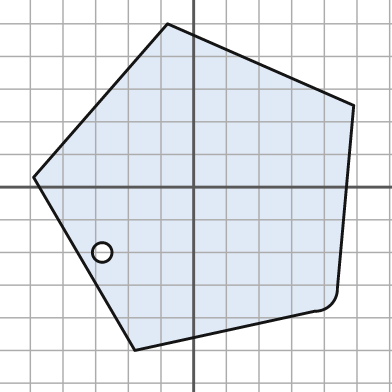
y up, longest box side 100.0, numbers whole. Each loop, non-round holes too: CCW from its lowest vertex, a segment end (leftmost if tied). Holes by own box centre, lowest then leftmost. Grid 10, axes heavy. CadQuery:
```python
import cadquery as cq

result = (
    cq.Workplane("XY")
    .moveTo(-18.0, -50.0)
    .lineTo(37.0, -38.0)
    .threePointArc((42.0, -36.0), (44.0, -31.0))
    .lineTo(49.0, 25.0)
    .lineTo(-8.0, 50.0)
    .lineTo(-49.0, 3.0)
    .close()
    .moveTo(-28.0, -20.0)
    .circle(3.0)
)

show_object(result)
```